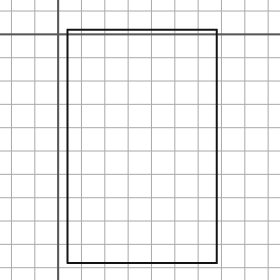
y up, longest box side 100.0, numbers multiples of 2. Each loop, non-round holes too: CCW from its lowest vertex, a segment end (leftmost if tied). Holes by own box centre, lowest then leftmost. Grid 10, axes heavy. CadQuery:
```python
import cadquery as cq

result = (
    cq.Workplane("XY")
    .moveTo(4.0, -98.0)
    .lineTo(68.0, -98.0)
    .lineTo(68.0, 2.0)
    .lineTo(4.0, 2.0)
    .close()
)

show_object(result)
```